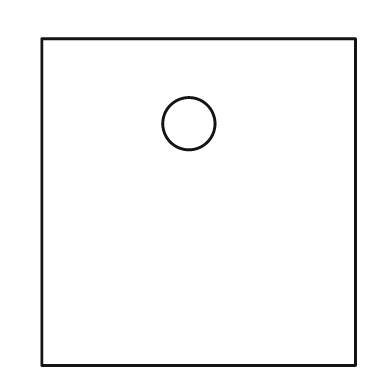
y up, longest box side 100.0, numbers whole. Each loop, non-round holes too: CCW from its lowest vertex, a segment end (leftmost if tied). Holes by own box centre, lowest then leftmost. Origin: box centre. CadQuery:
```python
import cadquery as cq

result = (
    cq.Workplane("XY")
    .moveTo(-48.0, -50.0)
    .lineTo(48.0, -50.0)
    .lineTo(48.0, 50.0)
    .lineTo(-48.0, 50.0)
    .close()
    .moveTo(-3.0, 24.0)
    .circle(8.0)
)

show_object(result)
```